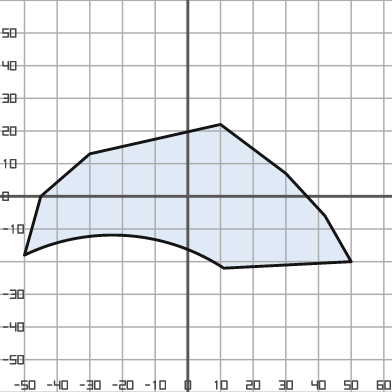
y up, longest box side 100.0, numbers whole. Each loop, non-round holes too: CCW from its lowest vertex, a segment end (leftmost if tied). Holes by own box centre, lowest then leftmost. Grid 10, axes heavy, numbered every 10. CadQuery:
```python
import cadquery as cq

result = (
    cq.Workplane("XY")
    .moveTo(11.0, -22.0)
    .lineTo(50.0, -20.0)
    .lineTo(42.0, -6.0)
    .lineTo(30.0, 7.0)
    .lineTo(10.0, 22.0)
    .lineTo(-30.0, 13.0)
    .lineTo(-45.0, 0.0)
    .lineTo(-50.0, -18.0)
    .threePointArc((-19.0, -12.0), (11.0, -22.0))
    .close()
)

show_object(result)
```